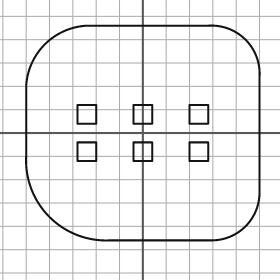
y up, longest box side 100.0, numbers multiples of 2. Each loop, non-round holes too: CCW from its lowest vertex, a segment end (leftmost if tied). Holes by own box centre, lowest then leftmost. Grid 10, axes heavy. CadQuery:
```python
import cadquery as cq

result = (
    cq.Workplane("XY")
    .moveTo(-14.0, -46.0)
    .lineTo(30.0, -46.0)
    .threePointArc((44.0, -40.0), (50.0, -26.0))
    .lineTo(50.0, 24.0)
    .threePointArc((44.0, 40.0), (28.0, 46.0))
    .lineTo(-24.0, 46.0)
    .threePointArc((-42.0, 38.0), (-50.0, 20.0))
    .lineTo(-50.0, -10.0)
    .threePointArc((-40.0, -36.0), (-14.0, -46.0))
    .close()
    .moveTo(-28.0, -12.0)
    .lineTo(-20.0, -12.0)
    .lineTo(-20.0, -4.0)
    .lineTo(-28.0, -4.0)
    .close()
    .moveTo(-4.0, -12.0)
    .lineTo(4.0, -12.0)
    .lineTo(4.0, -4.0)
    .lineTo(-4.0, -4.0)
    .close()
    .moveTo(20.0, -12.0)
    .lineTo(28.0, -12.0)
    .lineTo(28.0, -4.0)
    .lineTo(20.0, -4.0)
    .close()
    .moveTo(-28.0, 4.0)
    .lineTo(-20.0, 4.0)
    .lineTo(-20.0, 12.0)
    .lineTo(-28.0, 12.0)
    .close()
    .moveTo(-4.0, 4.0)
    .lineTo(4.0, 4.0)
    .lineTo(4.0, 12.0)
    .lineTo(-4.0, 12.0)
    .close()
    .moveTo(20.0, 4.0)
    .lineTo(28.0, 4.0)
    .lineTo(28.0, 12.0)
    .lineTo(20.0, 12.0)
    .close()
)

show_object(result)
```